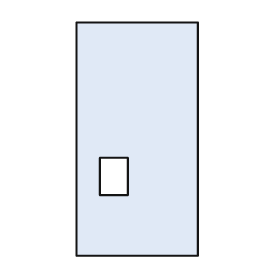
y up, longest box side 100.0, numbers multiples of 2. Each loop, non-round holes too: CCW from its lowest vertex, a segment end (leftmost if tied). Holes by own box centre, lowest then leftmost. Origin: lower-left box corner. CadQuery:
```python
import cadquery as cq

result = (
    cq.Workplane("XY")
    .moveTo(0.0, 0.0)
    .lineTo(52.0, 0.0)
    .lineTo(52.0, 100.0)
    .lineTo(0.0, 100.0)
    .close()
    .moveTo(10.0, 26.0)
    .lineTo(22.0, 26.0)
    .lineTo(22.0, 42.0)
    .lineTo(10.0, 42.0)
    .close()
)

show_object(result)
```